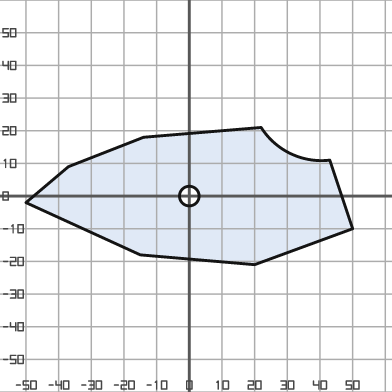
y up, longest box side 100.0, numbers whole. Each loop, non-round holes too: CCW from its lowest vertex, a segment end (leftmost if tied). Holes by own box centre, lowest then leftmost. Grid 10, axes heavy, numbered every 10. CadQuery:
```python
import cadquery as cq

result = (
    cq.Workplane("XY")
    .moveTo(20.0, -21.0)
    .lineTo(50.0, -10.0)
    .lineTo(43.0, 11.0)
    .threePointArc((31.0, 13.0), (22.0, 21.0))
    .lineTo(-14.0, 18.0)
    .lineTo(-37.0, 9.0)
    .lineTo(-50.0, -2.0)
    .lineTo(-15.0, -18.0)
    .close()
    .moveTo(0.0, 0.0)
    .circle(3.0)
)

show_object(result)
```